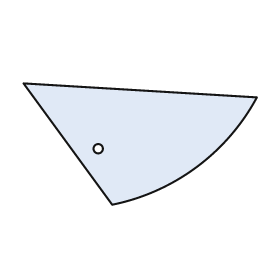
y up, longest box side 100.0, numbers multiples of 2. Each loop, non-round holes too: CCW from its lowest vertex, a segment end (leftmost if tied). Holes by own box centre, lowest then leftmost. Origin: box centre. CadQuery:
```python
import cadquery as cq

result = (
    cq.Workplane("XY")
    .moveTo(-12.0, -26.0)
    .threePointArc((24.0, -10.0), (50.0, 20.0))
    .lineTo(-50.0, 26.0)
    .close()
    .moveTo(-18.0, -2.0)
    .circle(2.0)
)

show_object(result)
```